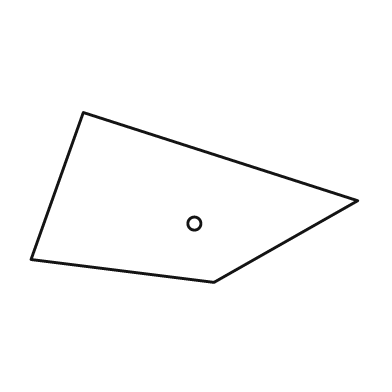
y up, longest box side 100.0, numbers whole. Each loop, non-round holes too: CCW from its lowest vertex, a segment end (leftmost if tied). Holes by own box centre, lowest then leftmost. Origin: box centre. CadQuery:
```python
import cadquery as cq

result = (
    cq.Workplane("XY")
    .moveTo(6.0, -26.0)
    .lineTo(50.0, -1.0)
    .lineTo(-34.0, 26.0)
    .lineTo(-50.0, -19.0)
    .close()
    .moveTo(0.0, -8.0)
    .circle(2.0)
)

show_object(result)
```